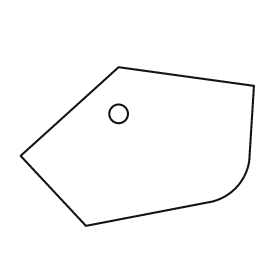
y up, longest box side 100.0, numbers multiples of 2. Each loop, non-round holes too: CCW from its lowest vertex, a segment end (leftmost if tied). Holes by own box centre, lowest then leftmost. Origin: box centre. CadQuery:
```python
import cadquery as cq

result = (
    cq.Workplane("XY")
    .moveTo(-22.0, -34.0)
    .lineTo(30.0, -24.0)
    .threePointArc((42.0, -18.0), (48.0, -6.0))
    .lineTo(50.0, 26.0)
    .lineTo(-8.0, 34.0)
    .lineTo(-50.0, -4.0)
    .close()
    .moveTo(-8.0, 14.0)
    .circle(4.0)
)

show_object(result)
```